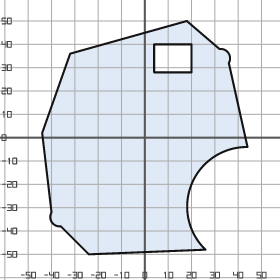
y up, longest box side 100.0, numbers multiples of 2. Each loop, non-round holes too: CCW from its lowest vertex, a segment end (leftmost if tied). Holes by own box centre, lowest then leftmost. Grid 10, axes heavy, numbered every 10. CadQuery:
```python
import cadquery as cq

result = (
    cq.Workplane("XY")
    .moveTo(-24.0, -50.0)
    .lineTo(26.0, -48.0)
    .threePointArc((20.0, -20.0), (44.0, -4.0))
    .lineTo(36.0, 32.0)
    .threePointArc((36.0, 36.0), (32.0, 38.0))
    .lineTo(18.0, 50.0)
    .lineTo(-32.0, 36.0)
    .lineTo(-44.0, 2.0)
    .lineTo(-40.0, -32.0)
    .threePointArc((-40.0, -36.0), (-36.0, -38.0))
    .close()
    .moveTo(4.0, 28.0)
    .lineTo(20.0, 28.0)
    .lineTo(20.0, 40.0)
    .lineTo(4.0, 40.0)
    .close()
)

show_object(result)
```